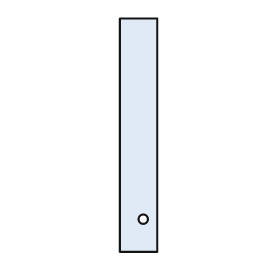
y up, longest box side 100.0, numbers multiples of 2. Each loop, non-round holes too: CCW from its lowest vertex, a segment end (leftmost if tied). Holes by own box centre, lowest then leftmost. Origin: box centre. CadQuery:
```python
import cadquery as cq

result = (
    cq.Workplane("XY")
    .moveTo(-8.0, -50.0)
    .lineTo(8.0, -50.0)
    .lineTo(8.0, 50.0)
    .lineTo(-8.0, 50.0)
    .close()
    .moveTo(2.0, -36.0)
    .circle(2.0)
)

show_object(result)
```